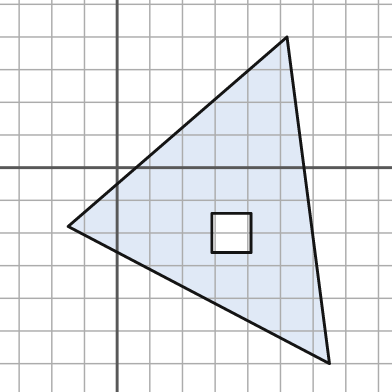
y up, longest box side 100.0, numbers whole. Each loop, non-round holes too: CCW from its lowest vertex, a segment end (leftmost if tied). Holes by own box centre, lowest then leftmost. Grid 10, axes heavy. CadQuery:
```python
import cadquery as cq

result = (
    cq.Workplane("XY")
    .moveTo(65.0, -60.0)
    .lineTo(52.0, 40.0)
    .lineTo(-15.0, -18.0)
    .close()
    .moveTo(29.0, -26.0)
    .lineTo(41.0, -26.0)
    .lineTo(41.0, -14.0)
    .lineTo(29.0, -14.0)
    .close()
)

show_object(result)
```